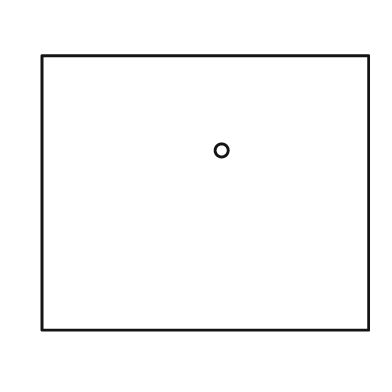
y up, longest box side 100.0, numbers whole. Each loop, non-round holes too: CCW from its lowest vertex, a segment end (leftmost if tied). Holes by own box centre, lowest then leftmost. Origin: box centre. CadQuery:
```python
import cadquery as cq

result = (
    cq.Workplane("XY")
    .moveTo(-50.0, -42.0)
    .lineTo(50.0, -42.0)
    .lineTo(50.0, 42.0)
    .lineTo(-50.0, 42.0)
    .close()
    .moveTo(5.0, 13.0)
    .circle(2.0)
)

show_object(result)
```